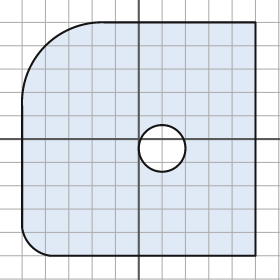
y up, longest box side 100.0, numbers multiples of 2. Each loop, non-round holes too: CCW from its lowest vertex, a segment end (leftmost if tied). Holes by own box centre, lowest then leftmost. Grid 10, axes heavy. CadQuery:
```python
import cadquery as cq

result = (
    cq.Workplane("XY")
    .moveTo(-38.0, -50.0)
    .lineTo(50.0, -50.0)
    .lineTo(50.0, 50.0)
    .lineTo(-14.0, 50.0)
    .threePointArc((-40.0, 40.0), (-50.0, 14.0))
    .lineTo(-50.0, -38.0)
    .threePointArc((-46.0, -46.0), (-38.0, -50.0))
    .close()
    .moveTo(10.0, -4.0)
    .circle(10.0)
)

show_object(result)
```